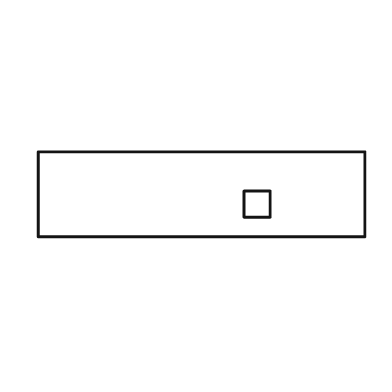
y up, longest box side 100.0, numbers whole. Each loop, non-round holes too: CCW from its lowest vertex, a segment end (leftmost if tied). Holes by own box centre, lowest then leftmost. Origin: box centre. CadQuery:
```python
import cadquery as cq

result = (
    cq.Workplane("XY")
    .moveTo(-50.0, -13.0)
    .lineTo(50.0, -13.0)
    .lineTo(50.0, 13.0)
    .lineTo(-50.0, 13.0)
    .close()
    .moveTo(13.0, -7.0)
    .lineTo(21.0, -7.0)
    .lineTo(21.0, 1.0)
    .lineTo(13.0, 1.0)
    .close()
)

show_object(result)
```